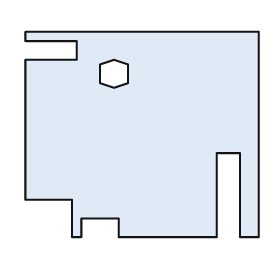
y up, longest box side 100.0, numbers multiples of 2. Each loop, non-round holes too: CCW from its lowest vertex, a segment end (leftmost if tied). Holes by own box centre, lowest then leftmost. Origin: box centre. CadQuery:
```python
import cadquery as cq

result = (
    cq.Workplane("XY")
    .moveTo(-30.0, -44.0)
    .lineTo(-26.0, -44.0)
    .lineTo(-26.0, -36.0)
    .lineTo(-10.0, -36.0)
    .lineTo(-10.0, -44.0)
    .lineTo(32.0, -44.0)
    .lineTo(32.0, -8.0)
    .lineTo(42.0, -8.0)
    .lineTo(42.0, -44.0)
    .lineTo(50.0, -44.0)
    .lineTo(50.0, 44.0)
    .lineTo(-50.0, 44.0)
    .lineTo(-50.0, 40.0)
    .lineTo(-28.0, 40.0)
    .lineTo(-28.0, 32.0)
    .lineTo(-50.0, 32.0)
    .lineTo(-50.0, -28.0)
    .lineTo(-30.0, -28.0)
    .close()
    .moveTo(-12.0, 20.0)
    .lineTo(-6.0, 22.0)
    .lineTo(-6.0, 30.0)
    .lineTo(-12.0, 32.0)
    .lineTo(-18.0, 30.0)
    .lineTo(-18.0, 22.0)
    .close()
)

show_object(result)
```